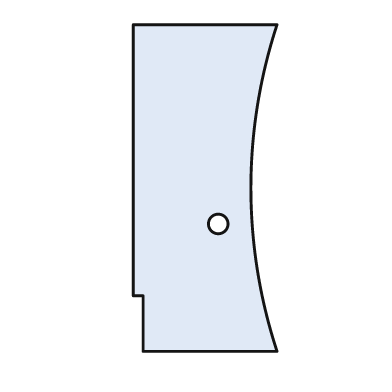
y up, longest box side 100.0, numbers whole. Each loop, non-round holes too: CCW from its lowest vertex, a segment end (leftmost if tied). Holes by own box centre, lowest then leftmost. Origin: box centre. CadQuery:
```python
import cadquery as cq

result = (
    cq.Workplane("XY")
    .moveTo(-19.0, -50.0)
    .lineTo(22.0, -50.0)
    .threePointArc((14.0, 0.0), (22.0, 50.0))
    .lineTo(-22.0, 50.0)
    .lineTo(-22.0, -33.0)
    .lineTo(-19.0, -33.0)
    .close()
    .moveTo(4.0, -11.0)
    .circle(3.0)
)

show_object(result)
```